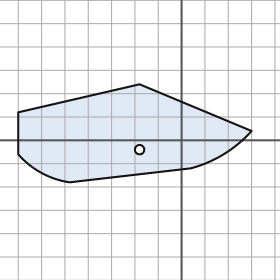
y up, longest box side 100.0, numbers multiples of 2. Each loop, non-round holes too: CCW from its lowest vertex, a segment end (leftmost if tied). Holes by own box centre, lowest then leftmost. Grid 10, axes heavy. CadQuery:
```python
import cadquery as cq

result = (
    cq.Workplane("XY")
    .moveTo(-48.0, -18.0)
    .lineTo(4.0, -12.0)
    .threePointArc((18.0, -6.0), (30.0, 4.0))
    .lineTo(-18.0, 24.0)
    .lineTo(-70.0, 12.0)
    .lineTo(-70.0, -6.0)
    .threePointArc((-60.0, -14.0), (-48.0, -18.0))
    .close()
    .moveTo(-18.0, -4.0)
    .circle(2.0)
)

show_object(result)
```